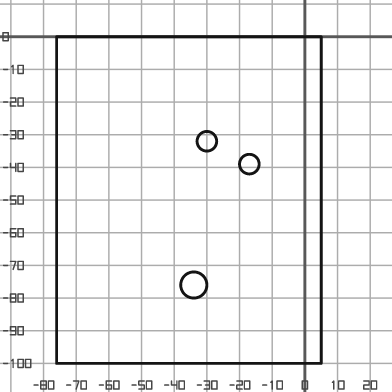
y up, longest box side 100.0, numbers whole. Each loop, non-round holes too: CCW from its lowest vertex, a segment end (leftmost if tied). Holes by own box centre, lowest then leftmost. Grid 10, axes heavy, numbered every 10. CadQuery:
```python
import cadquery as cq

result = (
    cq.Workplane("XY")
    .moveTo(-76.0, -100.0)
    .lineTo(5.0, -100.0)
    .lineTo(5.0, 0.0)
    .lineTo(-76.0, 0.0)
    .close()
    .moveTo(-34.0, -76.0)
    .circle(4.0)
    .moveTo(-17.0, -39.0)
    .circle(3.0)
    .moveTo(-30.0, -32.0)
    .circle(3.0)
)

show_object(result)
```